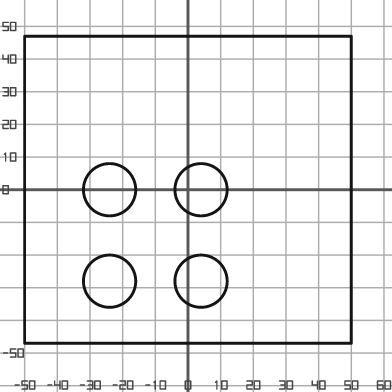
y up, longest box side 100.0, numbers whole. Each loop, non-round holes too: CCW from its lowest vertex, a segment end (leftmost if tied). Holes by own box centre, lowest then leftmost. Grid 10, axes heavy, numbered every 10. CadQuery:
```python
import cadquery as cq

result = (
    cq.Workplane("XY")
    .moveTo(-50.0, -47.0)
    .lineTo(50.0, -47.0)
    .lineTo(50.0, 47.0)
    .lineTo(-50.0, 47.0)
    .close()
    .moveTo(-24.0, -28.0)
    .circle(8.0)
    .moveTo(4.0, -28.0)
    .circle(8.0)
    .moveTo(-24.0, 0.0)
    .circle(8.0)
    .moveTo(4.0, 0.0)
    .circle(8.0)
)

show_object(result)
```